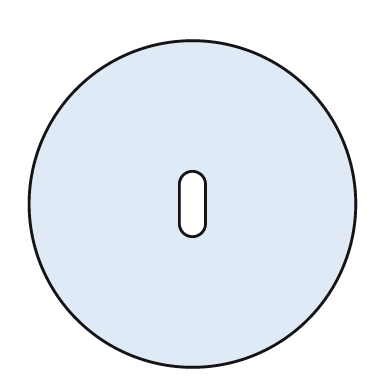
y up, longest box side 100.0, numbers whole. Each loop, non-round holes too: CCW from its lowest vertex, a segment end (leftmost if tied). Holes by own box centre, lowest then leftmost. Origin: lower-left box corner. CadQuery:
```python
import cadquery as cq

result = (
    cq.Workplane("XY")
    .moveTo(50.0, 50.0)
    .circle(50.0)
    .moveTo(46.0, 44.0)
    .threePointArc((50.0, 40.0), (54.0, 44.0))
    .lineTo(54.0, 56.0)
    .threePointArc((50.0, 60.0), (46.0, 56.0))
    .close()
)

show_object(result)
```